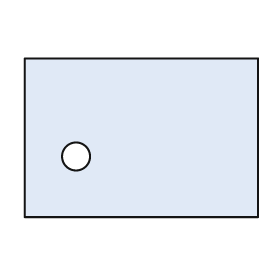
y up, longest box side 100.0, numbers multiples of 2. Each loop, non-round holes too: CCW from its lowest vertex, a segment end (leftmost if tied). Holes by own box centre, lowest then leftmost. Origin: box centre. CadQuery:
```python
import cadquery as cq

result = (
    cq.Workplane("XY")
    .moveTo(-50.0, -34.0)
    .lineTo(50.0, -34.0)
    .lineTo(50.0, 34.0)
    .lineTo(-50.0, 34.0)
    .close()
    .moveTo(-28.0, -8.0)
    .circle(6.0)
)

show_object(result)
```